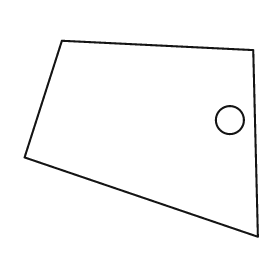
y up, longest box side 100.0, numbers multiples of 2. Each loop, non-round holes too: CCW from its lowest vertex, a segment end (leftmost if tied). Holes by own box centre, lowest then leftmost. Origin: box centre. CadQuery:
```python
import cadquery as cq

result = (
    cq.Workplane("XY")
    .moveTo(50.0, -42.0)
    .lineTo(48.0, 38.0)
    .lineTo(-34.0, 42.0)
    .lineTo(-50.0, -8.0)
    .close()
    .moveTo(38.0, 8.0)
    .circle(6.0)
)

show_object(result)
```